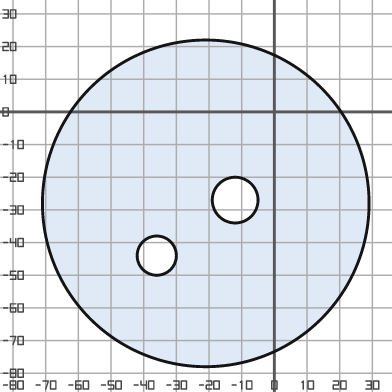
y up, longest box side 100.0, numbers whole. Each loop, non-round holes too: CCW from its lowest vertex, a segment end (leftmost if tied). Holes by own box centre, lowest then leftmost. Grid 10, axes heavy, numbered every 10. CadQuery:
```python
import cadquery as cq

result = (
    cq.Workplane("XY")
    .moveTo(-21.0, -28.0)
    .circle(50.0)
    .moveTo(-36.0, -44.0)
    .circle(6.0)
    .moveTo(-12.0, -27.0)
    .circle(7.0)
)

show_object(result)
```